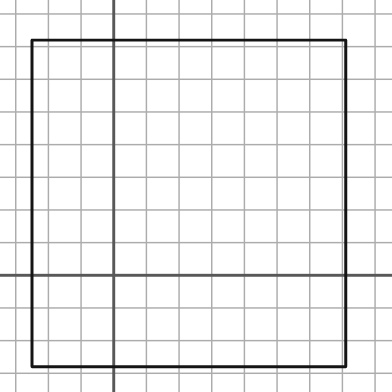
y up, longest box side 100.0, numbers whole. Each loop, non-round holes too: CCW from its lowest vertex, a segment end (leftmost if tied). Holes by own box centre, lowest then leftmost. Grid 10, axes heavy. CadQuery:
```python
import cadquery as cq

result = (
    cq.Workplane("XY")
    .moveTo(-25.0, -28.0)
    .lineTo(71.0, -28.0)
    .lineTo(71.0, 72.0)
    .lineTo(-25.0, 72.0)
    .close()
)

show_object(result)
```